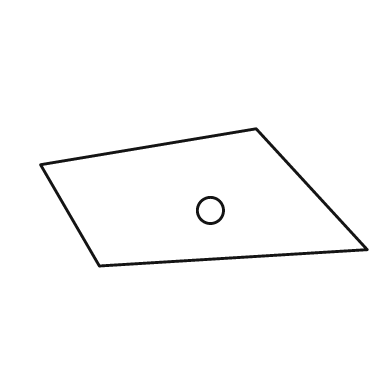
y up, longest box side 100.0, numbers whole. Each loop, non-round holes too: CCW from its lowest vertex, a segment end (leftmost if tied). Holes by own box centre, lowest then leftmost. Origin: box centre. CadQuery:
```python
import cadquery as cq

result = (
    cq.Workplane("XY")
    .moveTo(-32.0, -21.0)
    .lineTo(50.0, -16.0)
    .lineTo(16.0, 21.0)
    .lineTo(-50.0, 10.0)
    .close()
    .moveTo(2.0, -4.0)
    .circle(4.0)
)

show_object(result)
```